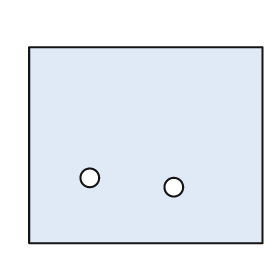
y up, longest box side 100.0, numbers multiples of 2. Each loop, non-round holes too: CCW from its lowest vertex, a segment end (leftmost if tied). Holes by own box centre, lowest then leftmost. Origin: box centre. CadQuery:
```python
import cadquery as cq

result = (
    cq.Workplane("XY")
    .moveTo(-50.0, -42.0)
    .lineTo(50.0, -42.0)
    .lineTo(50.0, 42.0)
    .lineTo(-50.0, 42.0)
    .close()
    .moveTo(12.0, -18.0)
    .circle(4.0)
    .moveTo(-24.0, -14.0)
    .circle(4.0)
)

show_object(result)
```